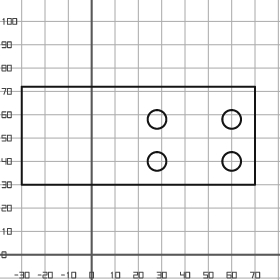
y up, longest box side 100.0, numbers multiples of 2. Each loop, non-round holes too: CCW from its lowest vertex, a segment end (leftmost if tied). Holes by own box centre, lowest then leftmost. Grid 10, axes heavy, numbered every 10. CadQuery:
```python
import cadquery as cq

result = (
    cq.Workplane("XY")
    .moveTo(-30.0, 30.0)
    .lineTo(70.0, 30.0)
    .lineTo(70.0, 72.0)
    .lineTo(-30.0, 72.0)
    .close()
    .moveTo(28.0, 40.0)
    .circle(4.0)
    .moveTo(60.0, 40.0)
    .circle(4.0)
    .moveTo(28.0, 58.0)
    .circle(4.0)
    .moveTo(60.0, 58.0)
    .circle(4.0)
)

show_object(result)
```